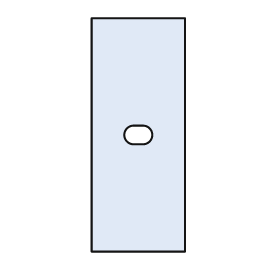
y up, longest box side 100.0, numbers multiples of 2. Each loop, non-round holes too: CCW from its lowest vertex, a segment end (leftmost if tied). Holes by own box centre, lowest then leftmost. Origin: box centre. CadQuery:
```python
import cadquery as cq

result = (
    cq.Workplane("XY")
    .moveTo(-20.0, -50.0)
    .lineTo(20.0, -50.0)
    .lineTo(20.0, 50.0)
    .lineTo(-20.0, 50.0)
    .close()
    .moveTo(-2.0, -4.0)
    .lineTo(2.0, -4.0)
    .threePointArc((6.0, 0.0), (2.0, 4.0))
    .lineTo(-2.0, 4.0)
    .threePointArc((-6.0, 0.0), (-2.0, -4.0))
    .close()
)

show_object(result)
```